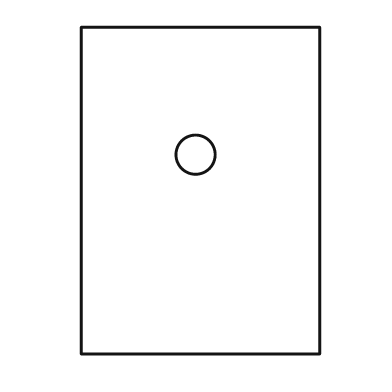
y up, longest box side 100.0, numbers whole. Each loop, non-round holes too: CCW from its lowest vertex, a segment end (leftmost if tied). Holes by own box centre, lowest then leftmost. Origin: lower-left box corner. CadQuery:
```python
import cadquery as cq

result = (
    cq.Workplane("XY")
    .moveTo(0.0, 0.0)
    .lineTo(73.0, 0.0)
    .lineTo(73.0, 100.0)
    .lineTo(0.0, 100.0)
    .close()
    .moveTo(35.0, 61.0)
    .circle(6.0)
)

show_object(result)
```